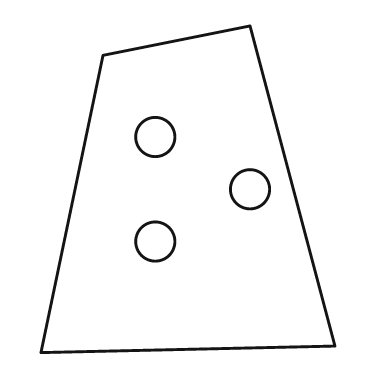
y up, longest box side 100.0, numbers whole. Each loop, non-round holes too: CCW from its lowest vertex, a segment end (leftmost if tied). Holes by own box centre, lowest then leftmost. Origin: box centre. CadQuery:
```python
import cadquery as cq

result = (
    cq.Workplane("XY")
    .moveTo(-45.0, -50.0)
    .lineTo(45.0, -48.0)
    .lineTo(19.0, 50.0)
    .lineTo(-26.0, 41.0)
    .close()
    .moveTo(-10.0, -16.0)
    .circle(6.0)
    .moveTo(19.0, 0.0)
    .circle(6.0)
    .moveTo(-10.0, 16.0)
    .circle(6.0)
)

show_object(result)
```